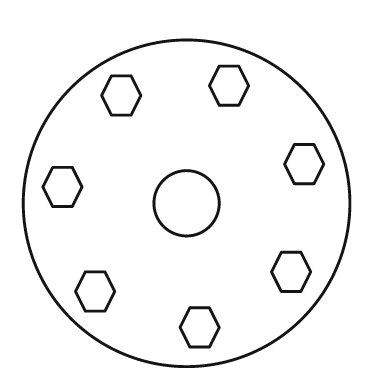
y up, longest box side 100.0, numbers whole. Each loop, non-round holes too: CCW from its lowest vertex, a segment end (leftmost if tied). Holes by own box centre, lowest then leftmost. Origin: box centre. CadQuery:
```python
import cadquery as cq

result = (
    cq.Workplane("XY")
    .moveTo(0.0, 0.0)
    .circle(50.0)
    .moveTo(1.0, -44.0)
    .lineTo(7.0, -44.0)
    .lineTo(10.0, -38.0)
    .lineTo(7.0, -32.0)
    .lineTo(1.0, -32.0)
    .lineTo(-2.0, -38.0)
    .close()
    .moveTo(-31.0, -33.0)
    .lineTo(-25.0, -33.0)
    .lineTo(-22.0, -27.0)
    .lineTo(-25.0, -21.0)
    .lineTo(-31.0, -21.0)
    .lineTo(-34.0, -27.0)
    .close()
    .moveTo(29.0, -27.0)
    .lineTo(35.0, -27.0)
    .lineTo(38.0, -21.0)
    .lineTo(35.0, -15.0)
    .lineTo(29.0, -15.0)
    .lineTo(26.0, -21.0)
    .close()
    .moveTo(0.0, 0.0)
    .circle(10.0)
    .moveTo(-41.0, -1.0)
    .lineTo(-35.0, -1.0)
    .lineTo(-32.0, 5.0)
    .lineTo(-35.0, 11.0)
    .lineTo(-41.0, 11.0)
    .lineTo(-44.0, 5.0)
    .close()
    .moveTo(33.0, 6.0)
    .lineTo(39.0, 6.0)
    .lineTo(42.0, 12.0)
    .lineTo(39.0, 18.0)
    .lineTo(33.0, 18.0)
    .lineTo(30.0, 12.0)
    .close()
    .moveTo(-23.0, 27.0)
    .lineTo(-17.0, 27.0)
    .lineTo(-14.0, 33.0)
    .lineTo(-17.0, 39.0)
    .lineTo(-23.0, 39.0)
    .lineTo(-26.0, 33.0)
    .close()
    .moveTo(10.0, 30.0)
    .lineTo(16.0, 30.0)
    .lineTo(19.0, 36.0)
    .lineTo(16.0, 42.0)
    .lineTo(10.0, 42.0)
    .lineTo(7.0, 36.0)
    .close()
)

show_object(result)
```